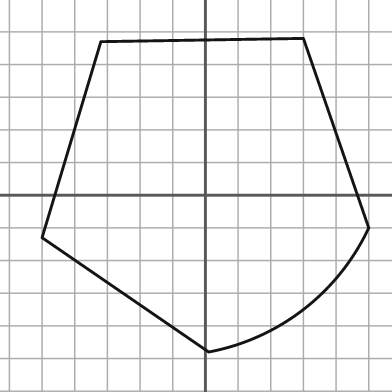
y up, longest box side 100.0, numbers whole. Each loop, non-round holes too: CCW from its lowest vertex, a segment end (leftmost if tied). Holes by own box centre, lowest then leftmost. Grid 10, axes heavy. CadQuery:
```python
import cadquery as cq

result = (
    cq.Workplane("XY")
    .moveTo(1.0, -48.0)
    .threePointArc((30.0, -35.0), (50.0, -10.0))
    .lineTo(30.0, 48.0)
    .lineTo(-32.0, 47.0)
    .lineTo(-50.0, -13.0)
    .close()
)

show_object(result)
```